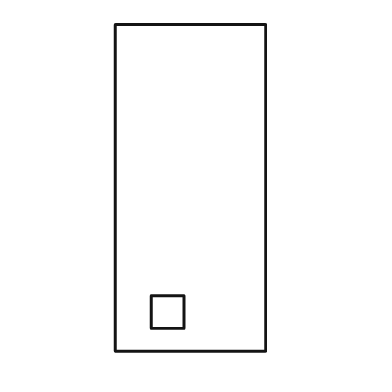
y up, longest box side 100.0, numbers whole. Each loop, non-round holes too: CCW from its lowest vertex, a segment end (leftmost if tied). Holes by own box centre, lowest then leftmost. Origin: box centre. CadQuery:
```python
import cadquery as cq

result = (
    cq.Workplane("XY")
    .moveTo(-23.0, -50.0)
    .lineTo(23.0, -50.0)
    .lineTo(23.0, 50.0)
    .lineTo(-23.0, 50.0)
    .close()
    .moveTo(-12.0, -43.0)
    .lineTo(-2.0, -43.0)
    .lineTo(-2.0, -33.0)
    .lineTo(-12.0, -33.0)
    .close()
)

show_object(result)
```